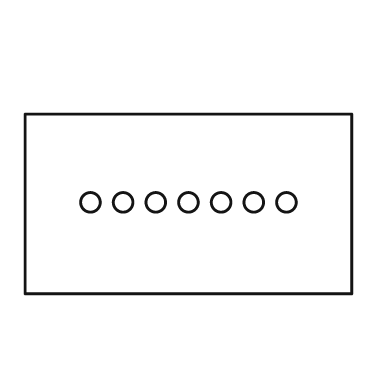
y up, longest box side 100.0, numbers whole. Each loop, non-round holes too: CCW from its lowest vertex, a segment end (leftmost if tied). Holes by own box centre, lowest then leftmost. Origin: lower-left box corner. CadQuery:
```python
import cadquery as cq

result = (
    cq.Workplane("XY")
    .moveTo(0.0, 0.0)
    .lineTo(100.0, 0.0)
    .lineTo(100.0, 55.0)
    .lineTo(0.0, 55.0)
    .close()
    .moveTo(20.0, 28.0)
    .circle(3.0)
    .moveTo(30.0, 28.0)
    .circle(3.0)
    .moveTo(40.0, 28.0)
    .circle(3.0)
    .moveTo(50.0, 28.0)
    .circle(3.0)
    .moveTo(60.0, 28.0)
    .circle(3.0)
    .moveTo(70.0, 28.0)
    .circle(3.0)
    .moveTo(80.0, 28.0)
    .circle(3.0)
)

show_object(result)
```